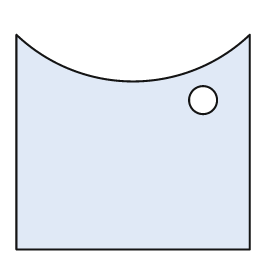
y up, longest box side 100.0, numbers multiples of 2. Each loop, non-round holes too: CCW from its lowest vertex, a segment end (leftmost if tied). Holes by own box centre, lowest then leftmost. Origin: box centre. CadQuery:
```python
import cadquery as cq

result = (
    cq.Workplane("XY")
    .moveTo(-50.0, -46.0)
    .lineTo(50.0, -46.0)
    .lineTo(50.0, 46.0)
    .threePointArc((0.0, 26.0), (-50.0, 46.0))
    .close()
    .moveTo(30.0, 18.0)
    .circle(6.0)
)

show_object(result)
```